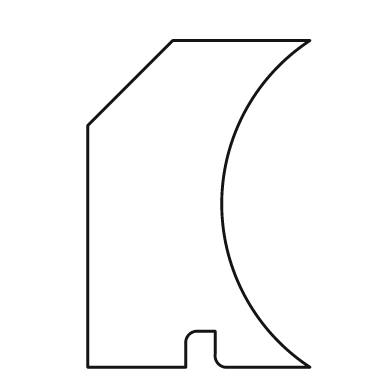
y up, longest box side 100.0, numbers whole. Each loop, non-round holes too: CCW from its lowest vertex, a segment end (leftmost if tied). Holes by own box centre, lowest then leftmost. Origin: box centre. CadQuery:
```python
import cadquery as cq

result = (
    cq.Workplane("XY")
    .moveTo(-34.0, -50.0)
    .lineTo(-4.0, -50.0)
    .lineTo(-4.0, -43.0)
    .threePointArc((-3.0, -40.0), (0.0, -39.0))
    .lineTo(5.0, -39.0)
    .lineTo(5.0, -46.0)
    .threePointArc((6.0, -49.0), (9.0, -50.0))
    .lineTo(34.0, -50.0)
    .threePointArc((7.0, 0.0), (34.0, 50.0))
    .lineTo(-8.0, 50.0)
    .lineTo(-34.0, 24.0)
    .close()
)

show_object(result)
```